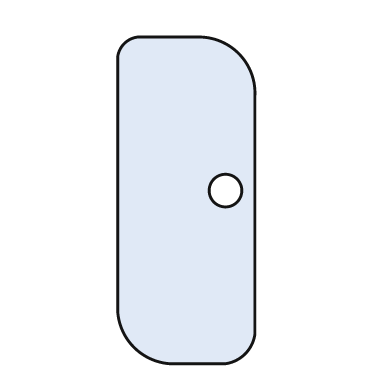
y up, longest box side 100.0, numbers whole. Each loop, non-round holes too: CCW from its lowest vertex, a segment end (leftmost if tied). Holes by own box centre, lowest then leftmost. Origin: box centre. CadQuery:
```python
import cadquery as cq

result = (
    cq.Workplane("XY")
    .moveTo(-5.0, -50.0)
    .lineTo(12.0, -50.0)
    .threePointArc((18.0, -47.0), (21.0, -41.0))
    .lineTo(21.0, 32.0)
    .threePointArc((16.0, 45.0), (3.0, 50.0))
    .lineTo(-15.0, 50.0)
    .threePointArc((-19.0, 48.0), (-21.0, 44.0))
    .lineTo(-21.0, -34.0)
    .threePointArc((-16.0, -45.0), (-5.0, -50.0))
    .close()
    .moveTo(12.0, 3.0)
    .circle(5.0)
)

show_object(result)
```